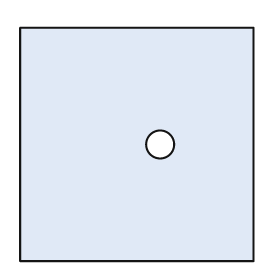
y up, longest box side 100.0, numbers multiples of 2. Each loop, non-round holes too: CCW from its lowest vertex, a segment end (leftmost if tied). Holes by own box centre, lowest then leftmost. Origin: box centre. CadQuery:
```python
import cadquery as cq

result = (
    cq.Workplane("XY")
    .moveTo(-50.0, -50.0)
    .lineTo(50.0, -50.0)
    .lineTo(50.0, 50.0)
    .lineTo(-50.0, 50.0)
    .close()
    .moveTo(10.0, 0.0)
    .circle(6.0)
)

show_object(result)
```